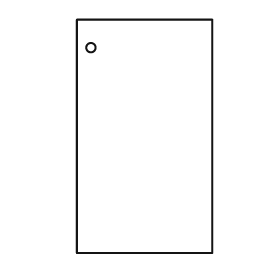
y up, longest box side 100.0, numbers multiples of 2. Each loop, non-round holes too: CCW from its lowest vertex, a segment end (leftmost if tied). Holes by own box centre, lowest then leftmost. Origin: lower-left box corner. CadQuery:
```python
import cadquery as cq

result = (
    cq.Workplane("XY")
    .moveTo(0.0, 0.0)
    .lineTo(58.0, 0.0)
    .lineTo(58.0, 100.0)
    .lineTo(0.0, 100.0)
    .close()
    .moveTo(6.0, 88.0)
    .circle(2.0)
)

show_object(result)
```